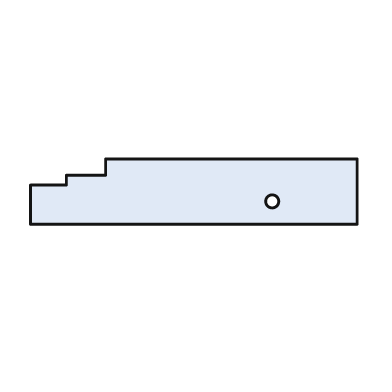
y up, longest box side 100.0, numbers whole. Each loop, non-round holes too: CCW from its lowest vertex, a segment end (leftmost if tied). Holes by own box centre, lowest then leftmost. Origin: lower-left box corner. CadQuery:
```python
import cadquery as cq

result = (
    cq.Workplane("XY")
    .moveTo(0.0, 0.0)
    .lineTo(100.0, 0.0)
    .lineTo(100.0, 20.0)
    .lineTo(23.0, 20.0)
    .lineTo(23.0, 15.0)
    .lineTo(11.0, 15.0)
    .lineTo(11.0, 12.0)
    .lineTo(0.0, 12.0)
    .close()
    .moveTo(74.0, 7.0)
    .circle(2.0)
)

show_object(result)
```